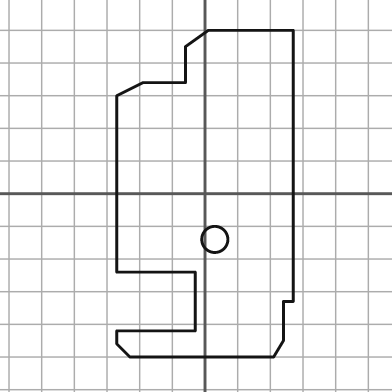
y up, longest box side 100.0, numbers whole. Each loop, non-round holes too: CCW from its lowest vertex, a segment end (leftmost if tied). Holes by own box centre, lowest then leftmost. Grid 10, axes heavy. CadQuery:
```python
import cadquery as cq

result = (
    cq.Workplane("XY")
    .moveTo(-23.0, -50.0)
    .lineTo(21.0, -50.0)
    .lineTo(24.0, -45.0)
    .lineTo(24.0, -33.0)
    .lineTo(27.0, -33.0)
    .lineTo(27.0, 50.0)
    .lineTo(1.0, 50.0)
    .lineTo(-6.0, 45.0)
    .lineTo(-6.0, 34.0)
    .lineTo(-19.0, 34.0)
    .lineTo(-27.0, 30.0)
    .lineTo(-27.0, -24.0)
    .lineTo(-3.0, -24.0)
    .lineTo(-3.0, -42.0)
    .lineTo(-27.0, -42.0)
    .lineTo(-27.0, -46.0)
    .close()
    .moveTo(3.0, -14.0)
    .circle(4.0)
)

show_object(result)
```